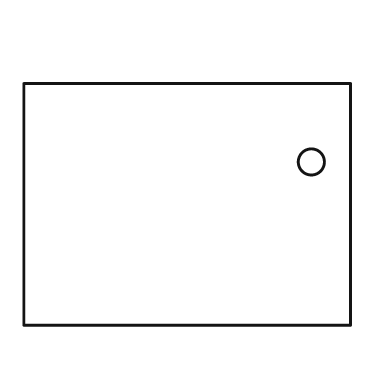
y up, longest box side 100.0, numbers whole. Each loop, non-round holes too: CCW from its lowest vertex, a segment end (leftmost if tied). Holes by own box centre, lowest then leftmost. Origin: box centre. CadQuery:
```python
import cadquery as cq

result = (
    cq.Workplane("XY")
    .moveTo(-50.0, -37.0)
    .lineTo(50.0, -37.0)
    .lineTo(50.0, 37.0)
    .lineTo(-50.0, 37.0)
    .close()
    .moveTo(38.0, 13.0)
    .circle(4.0)
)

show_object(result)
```